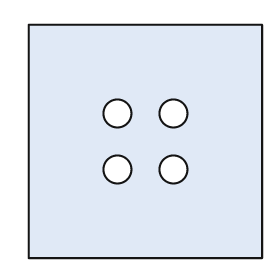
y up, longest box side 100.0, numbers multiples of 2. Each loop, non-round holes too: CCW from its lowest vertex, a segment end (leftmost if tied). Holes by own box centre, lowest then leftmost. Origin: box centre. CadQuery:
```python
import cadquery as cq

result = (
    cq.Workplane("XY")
    .moveTo(-50.0, -50.0)
    .lineTo(50.0, -50.0)
    .lineTo(50.0, 50.0)
    .lineTo(-50.0, 50.0)
    .close()
    .moveTo(-12.0, -12.0)
    .circle(6.0)
    .moveTo(12.0, -12.0)
    .circle(6.0)
    .moveTo(-12.0, 12.0)
    .circle(6.0)
    .moveTo(12.0, 12.0)
    .circle(6.0)
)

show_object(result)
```